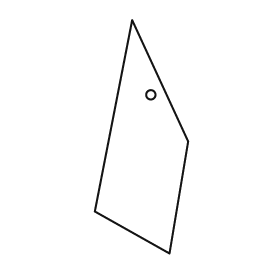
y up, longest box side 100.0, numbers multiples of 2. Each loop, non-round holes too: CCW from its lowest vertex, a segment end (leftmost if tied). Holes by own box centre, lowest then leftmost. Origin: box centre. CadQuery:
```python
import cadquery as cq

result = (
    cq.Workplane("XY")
    .moveTo(12.0, -50.0)
    .lineTo(20.0, -2.0)
    .lineTo(-4.0, 50.0)
    .lineTo(-20.0, -32.0)
    .close()
    .moveTo(4.0, 18.0)
    .circle(2.0)
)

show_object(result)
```